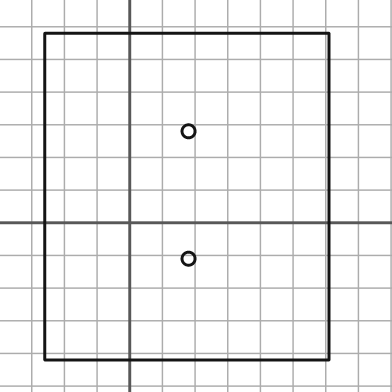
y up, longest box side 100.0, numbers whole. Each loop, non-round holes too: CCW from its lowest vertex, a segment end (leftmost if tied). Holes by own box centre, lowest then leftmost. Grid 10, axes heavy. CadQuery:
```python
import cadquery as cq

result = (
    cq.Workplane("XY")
    .moveTo(-26.0, -42.0)
    .lineTo(61.0, -42.0)
    .lineTo(61.0, 58.0)
    .lineTo(-26.0, 58.0)
    .close()
    .moveTo(18.0, -11.0)
    .circle(2.0)
    .moveTo(18.0, 28.0)
    .circle(2.0)
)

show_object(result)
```